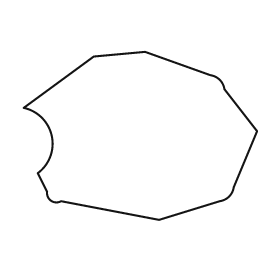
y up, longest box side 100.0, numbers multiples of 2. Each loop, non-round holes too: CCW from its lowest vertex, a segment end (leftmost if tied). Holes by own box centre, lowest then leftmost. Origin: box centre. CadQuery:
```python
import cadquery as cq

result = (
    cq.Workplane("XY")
    .moveTo(8.0, -36.0)
    .lineTo(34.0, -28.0)
    .threePointArc((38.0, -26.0), (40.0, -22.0))
    .lineTo(50.0, 2.0)
    .lineTo(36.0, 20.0)
    .threePointArc((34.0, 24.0), (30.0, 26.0))
    .lineTo(2.0, 36.0)
    .lineTo(-20.0, 34.0)
    .lineTo(-50.0, 12.0)
    .threePointArc((-38.0, 0.0), (-44.0, -16.0))
    .lineTo(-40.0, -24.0)
    .threePointArc((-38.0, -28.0), (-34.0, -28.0))
    .close()
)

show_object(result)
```